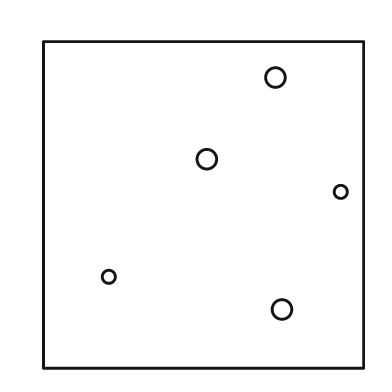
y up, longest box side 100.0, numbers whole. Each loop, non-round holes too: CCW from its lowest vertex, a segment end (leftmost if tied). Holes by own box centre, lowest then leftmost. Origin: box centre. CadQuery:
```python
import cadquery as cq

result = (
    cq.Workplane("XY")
    .moveTo(-49.0, -50.0)
    .lineTo(49.0, -50.0)
    .lineTo(49.0, 50.0)
    .lineTo(-49.0, 50.0)
    .close()
    .moveTo(24.0, -32.0)
    .circle(3.0)
    .moveTo(-29.0, -22.0)
    .circle(2.0)
    .moveTo(42.0, 4.0)
    .circle(2.0)
    .moveTo(1.0, 14.0)
    .circle(3.0)
    .moveTo(22.0, 39.0)
    .circle(3.0)
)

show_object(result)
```